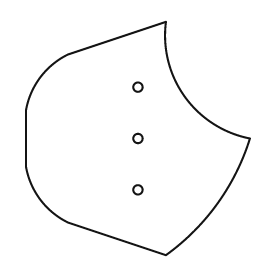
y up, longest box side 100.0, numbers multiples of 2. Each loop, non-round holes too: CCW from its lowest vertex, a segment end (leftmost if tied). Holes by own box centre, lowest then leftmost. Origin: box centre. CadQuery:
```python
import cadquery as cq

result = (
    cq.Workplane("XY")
    .moveTo(12.0, -50.0)
    .threePointArc((34.0, -28.0), (48.0, 0.0))
    .threePointArc((20.0, 18.0), (12.0, 50.0))
    .lineTo(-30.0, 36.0)
    .threePointArc((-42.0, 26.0), (-48.0, 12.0))
    .lineTo(-48.0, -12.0)
    .threePointArc((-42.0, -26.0), (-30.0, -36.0))
    .close()
    .moveTo(0.0, -22.0)
    .circle(2.0)
    .moveTo(0.0, 0.0)
    .circle(2.0)
    .moveTo(0.0, 22.0)
    .circle(2.0)
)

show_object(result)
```